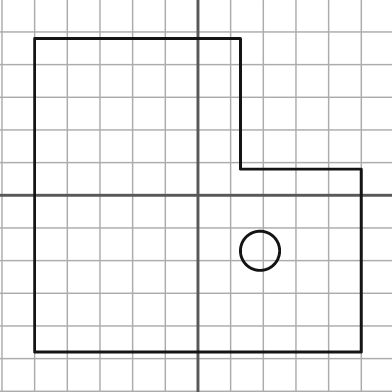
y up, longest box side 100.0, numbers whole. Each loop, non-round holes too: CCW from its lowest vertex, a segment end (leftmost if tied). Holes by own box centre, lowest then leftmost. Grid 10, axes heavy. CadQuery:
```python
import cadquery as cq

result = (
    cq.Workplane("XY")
    .moveTo(-50.0, -48.0)
    .lineTo(50.0, -48.0)
    .lineTo(50.0, 8.0)
    .lineTo(13.0, 8.0)
    .lineTo(13.0, 48.0)
    .lineTo(-50.0, 48.0)
    .close()
    .moveTo(19.0, -17.0)
    .circle(6.0)
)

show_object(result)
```